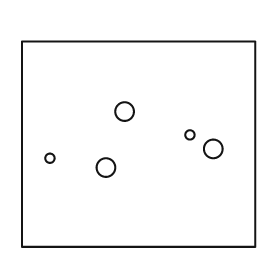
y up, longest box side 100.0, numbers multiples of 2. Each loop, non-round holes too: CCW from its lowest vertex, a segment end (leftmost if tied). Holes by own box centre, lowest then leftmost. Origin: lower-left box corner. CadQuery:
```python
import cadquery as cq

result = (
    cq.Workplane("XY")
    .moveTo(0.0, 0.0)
    .lineTo(100.0, 0.0)
    .lineTo(100.0, 88.0)
    .lineTo(0.0, 88.0)
    .close()
    .moveTo(36.0, 34.0)
    .circle(4.0)
    .moveTo(12.0, 38.0)
    .circle(2.0)
    .moveTo(82.0, 42.0)
    .circle(4.0)
    .moveTo(72.0, 48.0)
    .circle(2.0)
    .moveTo(44.0, 58.0)
    .circle(4.0)
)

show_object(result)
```